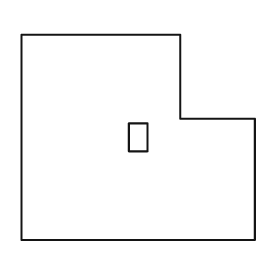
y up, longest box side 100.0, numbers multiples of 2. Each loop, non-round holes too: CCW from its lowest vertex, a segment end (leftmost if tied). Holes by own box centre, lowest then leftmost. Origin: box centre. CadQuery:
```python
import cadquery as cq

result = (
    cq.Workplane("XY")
    .moveTo(-50.0, -44.0)
    .lineTo(50.0, -44.0)
    .lineTo(50.0, 8.0)
    .lineTo(18.0, 8.0)
    .lineTo(18.0, 44.0)
    .lineTo(-50.0, 44.0)
    .close()
    .moveTo(-4.0, -6.0)
    .lineTo(4.0, -6.0)
    .lineTo(4.0, 6.0)
    .lineTo(-4.0, 6.0)
    .close()
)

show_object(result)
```